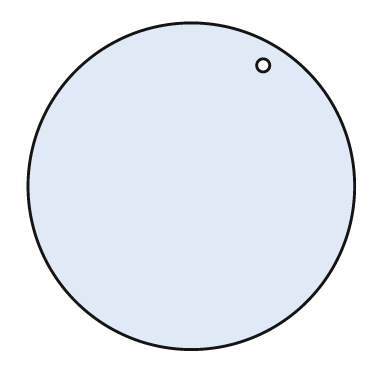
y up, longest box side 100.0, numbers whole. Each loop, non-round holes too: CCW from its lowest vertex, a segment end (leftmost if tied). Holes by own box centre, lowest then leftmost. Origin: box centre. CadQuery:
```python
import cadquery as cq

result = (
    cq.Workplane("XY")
    .moveTo(0.0, 0.0)
    .circle(50.0)
    .moveTo(22.0, 37.0)
    .circle(2.0)
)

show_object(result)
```